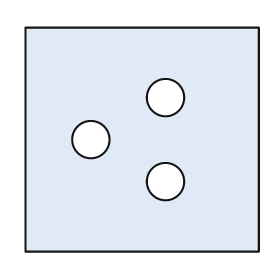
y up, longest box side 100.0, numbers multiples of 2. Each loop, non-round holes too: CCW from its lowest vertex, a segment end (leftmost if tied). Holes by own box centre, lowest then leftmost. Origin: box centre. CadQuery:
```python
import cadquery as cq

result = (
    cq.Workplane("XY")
    .moveTo(-50.0, -48.0)
    .lineTo(50.0, -48.0)
    .lineTo(50.0, 48.0)
    .lineTo(-50.0, 48.0)
    .close()
    .moveTo(10.0, -18.0)
    .circle(8.0)
    .moveTo(-22.0, 0.0)
    .circle(8.0)
    .moveTo(10.0, 18.0)
    .circle(8.0)
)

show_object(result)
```